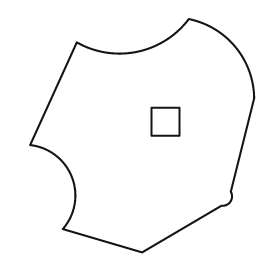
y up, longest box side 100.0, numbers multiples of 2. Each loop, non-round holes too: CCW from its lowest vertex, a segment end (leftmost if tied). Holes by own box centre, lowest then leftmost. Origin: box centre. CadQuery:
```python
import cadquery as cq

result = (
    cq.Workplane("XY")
    .moveTo(0.0, -50.0)
    .lineTo(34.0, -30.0)
    .threePointArc((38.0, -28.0), (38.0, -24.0))
    .lineTo(48.0, 16.0)
    .threePointArc((40.0, 38.0), (20.0, 50.0))
    .threePointArc((-2.0, 36.0), (-28.0, 40.0))
    .lineTo(-48.0, -4.0)
    .threePointArc((-30.0, -18.0), (-34.0, -40.0))
    .close()
    .moveTo(4.0, 0.0)
    .lineTo(16.0, 0.0)
    .lineTo(16.0, 12.0)
    .lineTo(4.0, 12.0)
    .close()
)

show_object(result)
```